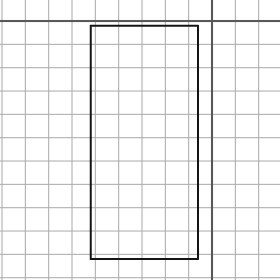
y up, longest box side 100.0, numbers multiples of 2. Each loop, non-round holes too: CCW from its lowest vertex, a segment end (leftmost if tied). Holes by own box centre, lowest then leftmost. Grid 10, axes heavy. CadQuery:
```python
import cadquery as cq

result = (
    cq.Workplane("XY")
    .moveTo(-52.0, -102.0)
    .lineTo(-6.0, -102.0)
    .lineTo(-6.0, -2.0)
    .lineTo(-52.0, -2.0)
    .close()
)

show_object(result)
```